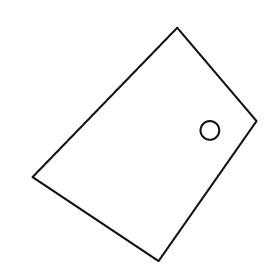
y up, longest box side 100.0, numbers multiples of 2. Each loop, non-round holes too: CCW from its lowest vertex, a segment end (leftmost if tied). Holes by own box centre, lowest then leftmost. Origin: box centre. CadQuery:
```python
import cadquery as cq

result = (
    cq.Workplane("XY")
    .moveTo(6.0, -50.0)
    .lineTo(48.0, 10.0)
    .lineTo(14.0, 50.0)
    .lineTo(-48.0, -14.0)
    .close()
    .moveTo(28.0, 6.0)
    .circle(4.0)
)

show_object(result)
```